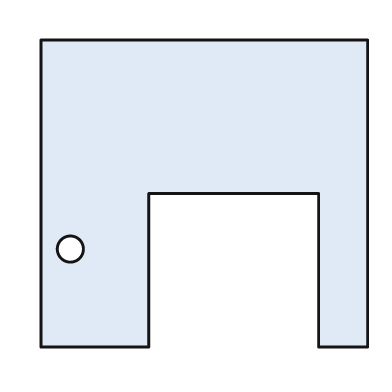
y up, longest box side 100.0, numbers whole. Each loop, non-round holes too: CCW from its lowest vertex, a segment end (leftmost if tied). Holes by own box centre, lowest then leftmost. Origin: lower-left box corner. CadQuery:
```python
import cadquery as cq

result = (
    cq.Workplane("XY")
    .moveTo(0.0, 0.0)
    .lineTo(33.0, 0.0)
    .lineTo(33.0, 47.0)
    .lineTo(85.0, 47.0)
    .lineTo(85.0, 0.0)
    .lineTo(100.0, 0.0)
    .lineTo(100.0, 94.0)
    .lineTo(0.0, 94.0)
    .close()
    .moveTo(9.0, 30.0)
    .circle(4.0)
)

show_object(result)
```